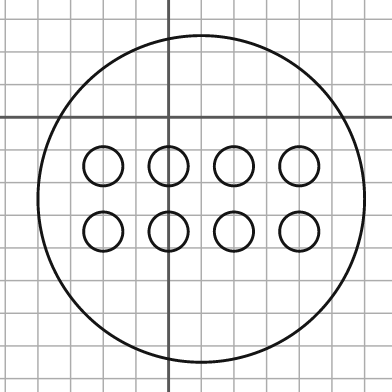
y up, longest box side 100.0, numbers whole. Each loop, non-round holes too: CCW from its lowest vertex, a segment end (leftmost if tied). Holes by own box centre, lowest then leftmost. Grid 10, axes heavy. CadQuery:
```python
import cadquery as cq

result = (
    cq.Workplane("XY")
    .moveTo(10.0, -25.0)
    .circle(50.0)
    .moveTo(-20.0, -35.0)
    .circle(6.0)
    .moveTo(0.0, -35.0)
    .circle(6.0)
    .moveTo(20.0, -35.0)
    .circle(6.0)
    .moveTo(40.0, -35.0)
    .circle(6.0)
    .moveTo(-20.0, -15.0)
    .circle(6.0)
    .moveTo(0.0, -15.0)
    .circle(6.0)
    .moveTo(20.0, -15.0)
    .circle(6.0)
    .moveTo(40.0, -15.0)
    .circle(6.0)
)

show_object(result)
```